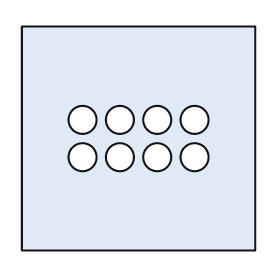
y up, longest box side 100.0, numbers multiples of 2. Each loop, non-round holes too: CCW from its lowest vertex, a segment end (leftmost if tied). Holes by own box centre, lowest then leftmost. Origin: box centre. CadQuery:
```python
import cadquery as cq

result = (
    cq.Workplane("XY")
    .moveTo(-50.0, -48.0)
    .lineTo(50.0, -48.0)
    .lineTo(50.0, 48.0)
    .lineTo(-50.0, 48.0)
    .close()
    .moveTo(-24.0, -8.0)
    .circle(6.0)
    .moveTo(-8.0, -8.0)
    .circle(6.0)
    .moveTo(8.0, -8.0)
    .circle(6.0)
    .moveTo(24.0, -8.0)
    .circle(6.0)
    .moveTo(-24.0, 8.0)
    .circle(6.0)
    .moveTo(-8.0, 8.0)
    .circle(6.0)
    .moveTo(8.0, 8.0)
    .circle(6.0)
    .moveTo(24.0, 8.0)
    .circle(6.0)
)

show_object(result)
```